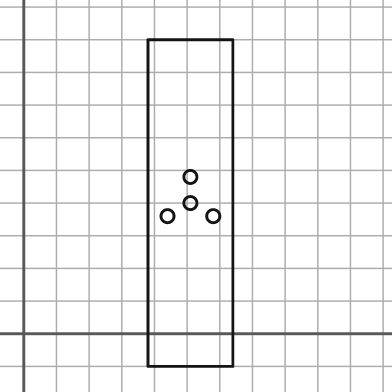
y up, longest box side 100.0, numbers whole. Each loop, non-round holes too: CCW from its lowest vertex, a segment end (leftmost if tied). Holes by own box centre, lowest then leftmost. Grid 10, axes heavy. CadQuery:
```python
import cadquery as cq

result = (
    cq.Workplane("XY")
    .moveTo(38.0, -10.0)
    .lineTo(64.0, -10.0)
    .lineTo(64.0, 90.0)
    .lineTo(38.0, 90.0)
    .close()
    .moveTo(44.0, 36.0)
    .circle(2.0)
    .moveTo(58.0, 36.0)
    .circle(2.0)
    .moveTo(51.0, 40.0)
    .circle(2.0)
    .moveTo(51.0, 48.0)
    .circle(2.0)
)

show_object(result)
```